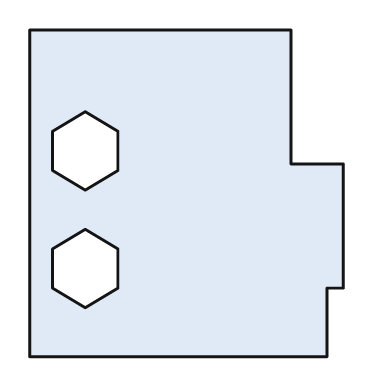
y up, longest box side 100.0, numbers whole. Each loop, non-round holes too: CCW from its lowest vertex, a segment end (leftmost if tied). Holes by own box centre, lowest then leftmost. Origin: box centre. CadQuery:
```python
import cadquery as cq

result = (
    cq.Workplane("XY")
    .moveTo(-48.0, -50.0)
    .lineTo(43.0, -50.0)
    .lineTo(43.0, -29.0)
    .lineTo(48.0, -29.0)
    .lineTo(48.0, 9.0)
    .lineTo(32.0, 9.0)
    .lineTo(32.0, 50.0)
    .lineTo(-48.0, 50.0)
    .close()
    .moveTo(-31.0, -35.0)
    .lineTo(-21.0, -29.0)
    .lineTo(-21.0, -17.0)
    .lineTo(-31.0, -11.0)
    .lineTo(-41.0, -17.0)
    .lineTo(-41.0, -29.0)
    .close()
    .moveTo(-31.0, 1.0)
    .lineTo(-21.0, 7.0)
    .lineTo(-21.0, 19.0)
    .lineTo(-31.0, 25.0)
    .lineTo(-41.0, 19.0)
    .lineTo(-41.0, 7.0)
    .close()
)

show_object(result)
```